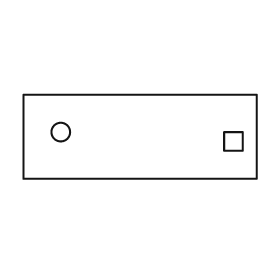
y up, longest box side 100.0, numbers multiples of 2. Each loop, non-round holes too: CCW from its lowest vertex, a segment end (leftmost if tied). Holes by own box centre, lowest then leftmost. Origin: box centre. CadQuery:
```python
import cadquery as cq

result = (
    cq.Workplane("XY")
    .moveTo(-50.0, -18.0)
    .lineTo(50.0, -18.0)
    .lineTo(50.0, 18.0)
    .lineTo(-50.0, 18.0)
    .close()
    .moveTo(36.0, -6.0)
    .lineTo(44.0, -6.0)
    .lineTo(44.0, 2.0)
    .lineTo(36.0, 2.0)
    .close()
    .moveTo(-34.0, 2.0)
    .circle(4.0)
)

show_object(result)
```